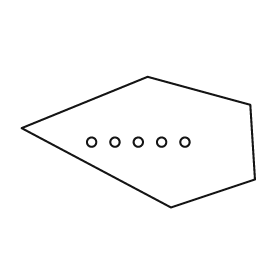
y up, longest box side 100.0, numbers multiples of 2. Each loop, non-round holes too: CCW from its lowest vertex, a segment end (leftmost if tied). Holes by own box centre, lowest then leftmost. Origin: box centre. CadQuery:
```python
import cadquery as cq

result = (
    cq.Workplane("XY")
    .moveTo(14.0, -28.0)
    .lineTo(50.0, -16.0)
    .lineTo(48.0, 16.0)
    .lineTo(4.0, 28.0)
    .lineTo(-50.0, 6.0)
    .close()
    .moveTo(-20.0, 0.0)
    .circle(2.0)
    .moveTo(-10.0, 0.0)
    .circle(2.0)
    .moveTo(0.0, 0.0)
    .circle(2.0)
    .moveTo(10.0, 0.0)
    .circle(2.0)
    .moveTo(20.0, 0.0)
    .circle(2.0)
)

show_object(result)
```